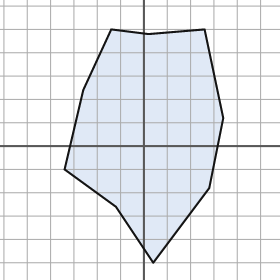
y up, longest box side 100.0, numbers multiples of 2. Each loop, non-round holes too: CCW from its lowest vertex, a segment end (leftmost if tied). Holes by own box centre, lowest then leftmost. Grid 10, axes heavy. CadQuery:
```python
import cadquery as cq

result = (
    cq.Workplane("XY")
    .moveTo(4.0, -50.0)
    .lineTo(28.0, -18.0)
    .lineTo(34.0, 12.0)
    .lineTo(26.0, 50.0)
    .lineTo(2.0, 48.0)
    .lineTo(-14.0, 50.0)
    .lineTo(-26.0, 24.0)
    .lineTo(-34.0, -10.0)
    .lineTo(-12.0, -26.0)
    .close()
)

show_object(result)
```